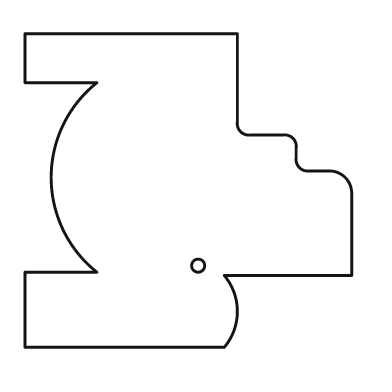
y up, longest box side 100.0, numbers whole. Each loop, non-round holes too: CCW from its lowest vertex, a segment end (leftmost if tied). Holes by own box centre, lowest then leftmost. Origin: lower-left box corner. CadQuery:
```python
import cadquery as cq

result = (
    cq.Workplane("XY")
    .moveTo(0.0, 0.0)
    .lineTo(61.0, 0.0)
    .threePointArc((65.0, 11.0), (61.0, 22.0))
    .lineTo(100.0, 22.0)
    .lineTo(100.0, 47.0)
    .threePointArc((98.0, 52.0), (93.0, 54.0))
    .lineTo(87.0, 54.0)
    .threePointArc((84.0, 55.0), (83.0, 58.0))
    .lineTo(83.0, 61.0)
    .threePointArc((82.0, 64.0), (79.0, 65.0))
    .lineTo(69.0, 65.0)
    .threePointArc((66.0, 66.0), (65.0, 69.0))
    .lineTo(65.0, 96.0)
    .lineTo(0.0, 96.0)
    .lineTo(0.0, 81.0)
    .lineTo(22.0, 81.0)
    .threePointArc((8.0, 52.0), (22.0, 23.0))
    .lineTo(0.0, 23.0)
    .close()
    .moveTo(53.0, 25.0)
    .circle(2.0)
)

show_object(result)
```